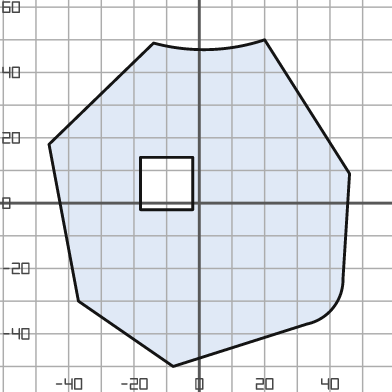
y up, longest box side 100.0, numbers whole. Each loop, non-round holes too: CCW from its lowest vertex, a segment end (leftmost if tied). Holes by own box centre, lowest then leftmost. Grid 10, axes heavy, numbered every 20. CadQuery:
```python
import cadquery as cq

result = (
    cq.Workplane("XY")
    .moveTo(-8.0, -50.0)
    .lineTo(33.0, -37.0)
    .threePointArc((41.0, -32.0), (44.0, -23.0))
    .lineTo(46.0, 9.0)
    .lineTo(20.0, 50.0)
    .threePointArc((3.0, 47.0), (-14.0, 49.0))
    .lineTo(-46.0, 18.0)
    .lineTo(-37.0, -30.0)
    .close()
    .moveTo(-18.0, -2.0)
    .lineTo(-2.0, -2.0)
    .lineTo(-2.0, 14.0)
    .lineTo(-18.0, 14.0)
    .close()
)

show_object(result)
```